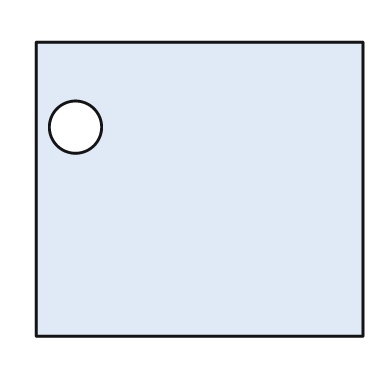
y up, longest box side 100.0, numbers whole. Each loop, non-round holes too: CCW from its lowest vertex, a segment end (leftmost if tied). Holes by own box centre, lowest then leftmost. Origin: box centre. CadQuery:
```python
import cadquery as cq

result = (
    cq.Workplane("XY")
    .moveTo(-50.0, -45.0)
    .lineTo(50.0, -45.0)
    .lineTo(50.0, 45.0)
    .lineTo(-50.0, 45.0)
    .close()
    .moveTo(-38.0, 19.0)
    .circle(8.0)
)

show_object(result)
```